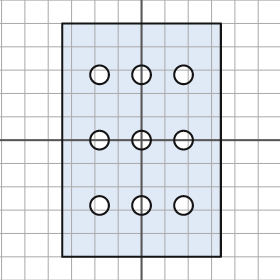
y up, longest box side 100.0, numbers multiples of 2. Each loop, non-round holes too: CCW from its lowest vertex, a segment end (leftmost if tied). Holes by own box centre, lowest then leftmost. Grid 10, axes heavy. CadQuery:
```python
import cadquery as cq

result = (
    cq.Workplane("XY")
    .moveTo(-34.0, -50.0)
    .lineTo(34.0, -50.0)
    .lineTo(34.0, 50.0)
    .lineTo(-34.0, 50.0)
    .close()
    .moveTo(-18.0, -28.0)
    .circle(4.0)
    .moveTo(0.0, -28.0)
    .circle(4.0)
    .moveTo(18.0, -28.0)
    .circle(4.0)
    .moveTo(-18.0, 0.0)
    .circle(4.0)
    .moveTo(0.0, 0.0)
    .circle(4.0)
    .moveTo(18.0, 0.0)
    .circle(4.0)
    .moveTo(-18.0, 28.0)
    .circle(4.0)
    .moveTo(0.0, 28.0)
    .circle(4.0)
    .moveTo(18.0, 28.0)
    .circle(4.0)
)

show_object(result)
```